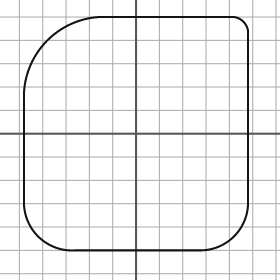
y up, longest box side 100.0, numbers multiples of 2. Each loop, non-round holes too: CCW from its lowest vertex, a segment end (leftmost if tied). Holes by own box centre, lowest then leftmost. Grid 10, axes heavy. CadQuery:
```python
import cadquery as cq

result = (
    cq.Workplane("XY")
    .moveTo(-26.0, -50.0)
    .lineTo(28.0, -50.0)
    .threePointArc((42.0, -44.0), (48.0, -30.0))
    .lineTo(48.0, 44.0)
    .threePointArc((46.0, 48.0), (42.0, 50.0))
    .lineTo(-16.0, 50.0)
    .threePointArc((-38.0, 40.0), (-48.0, 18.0))
    .lineTo(-48.0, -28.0)
    .threePointArc((-42.0, -44.0), (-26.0, -50.0))
    .close()
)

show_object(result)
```